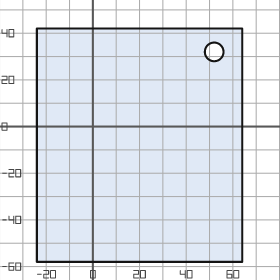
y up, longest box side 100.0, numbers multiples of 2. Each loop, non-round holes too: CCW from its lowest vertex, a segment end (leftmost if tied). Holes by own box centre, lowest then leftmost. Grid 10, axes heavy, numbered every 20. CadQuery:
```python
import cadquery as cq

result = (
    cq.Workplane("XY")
    .moveTo(-24.0, -58.0)
    .lineTo(64.0, -58.0)
    .lineTo(64.0, 42.0)
    .lineTo(-24.0, 42.0)
    .close()
    .moveTo(52.0, 32.0)
    .circle(4.0)
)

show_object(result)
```